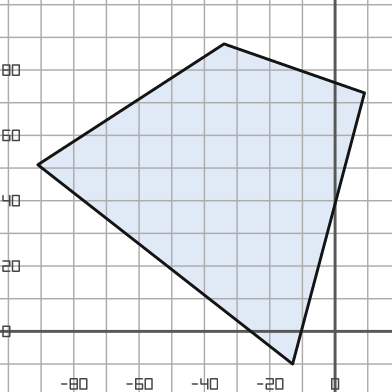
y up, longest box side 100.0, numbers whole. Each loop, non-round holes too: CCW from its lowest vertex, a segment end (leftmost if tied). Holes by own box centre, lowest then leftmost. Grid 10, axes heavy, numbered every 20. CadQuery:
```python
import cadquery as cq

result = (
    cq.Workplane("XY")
    .moveTo(-13.0, -10.0)
    .lineTo(9.0, 73.0)
    .lineTo(-34.0, 88.0)
    .lineTo(-91.0, 51.0)
    .close()
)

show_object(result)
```